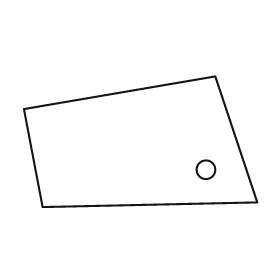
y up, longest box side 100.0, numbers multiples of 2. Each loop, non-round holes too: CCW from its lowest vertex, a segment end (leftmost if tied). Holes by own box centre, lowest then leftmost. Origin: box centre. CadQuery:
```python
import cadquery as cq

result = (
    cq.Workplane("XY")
    .moveTo(-42.0, -28.0)
    .lineTo(50.0, -26.0)
    .lineTo(32.0, 28.0)
    .lineTo(-50.0, 14.0)
    .close()
    .moveTo(28.0, -12.0)
    .circle(4.0)
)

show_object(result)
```